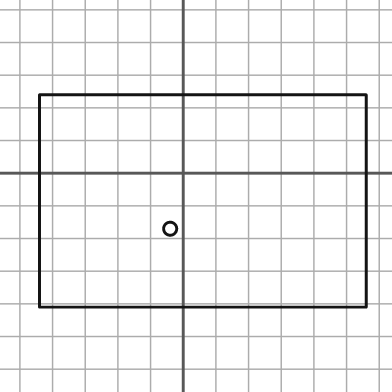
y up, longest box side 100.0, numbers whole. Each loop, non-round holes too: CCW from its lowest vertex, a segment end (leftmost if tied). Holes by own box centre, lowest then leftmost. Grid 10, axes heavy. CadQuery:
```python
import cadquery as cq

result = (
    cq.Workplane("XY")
    .moveTo(-44.0, -41.0)
    .lineTo(56.0, -41.0)
    .lineTo(56.0, 24.0)
    .lineTo(-44.0, 24.0)
    .close()
    .moveTo(-4.0, -17.0)
    .circle(2.0)
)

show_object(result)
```